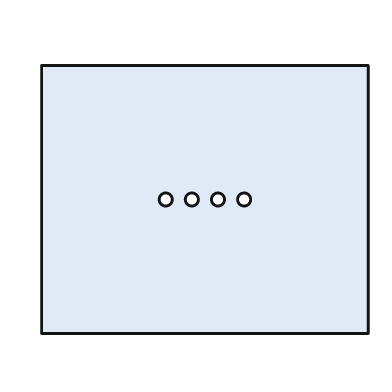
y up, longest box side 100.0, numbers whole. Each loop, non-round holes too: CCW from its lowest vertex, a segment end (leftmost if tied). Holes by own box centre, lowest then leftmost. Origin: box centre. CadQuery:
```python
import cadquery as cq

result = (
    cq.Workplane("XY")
    .moveTo(-50.0, -41.0)
    .lineTo(50.0, -41.0)
    .lineTo(50.0, 41.0)
    .lineTo(-50.0, 41.0)
    .close()
    .moveTo(-12.0, 0.0)
    .circle(2.0)
    .moveTo(-4.0, 0.0)
    .circle(2.0)
    .moveTo(4.0, 0.0)
    .circle(2.0)
    .moveTo(12.0, 0.0)
    .circle(2.0)
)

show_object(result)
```